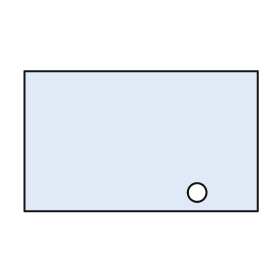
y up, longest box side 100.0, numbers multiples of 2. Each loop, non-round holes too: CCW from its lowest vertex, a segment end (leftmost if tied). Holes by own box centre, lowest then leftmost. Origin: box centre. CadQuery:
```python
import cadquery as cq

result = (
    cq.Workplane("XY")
    .moveTo(-50.0, -30.0)
    .lineTo(50.0, -30.0)
    .lineTo(50.0, 30.0)
    .lineTo(-50.0, 30.0)
    .close()
    .moveTo(24.0, -22.0)
    .circle(4.0)
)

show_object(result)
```